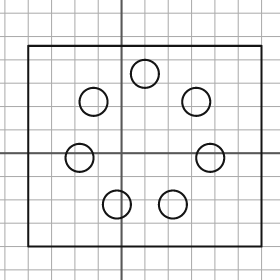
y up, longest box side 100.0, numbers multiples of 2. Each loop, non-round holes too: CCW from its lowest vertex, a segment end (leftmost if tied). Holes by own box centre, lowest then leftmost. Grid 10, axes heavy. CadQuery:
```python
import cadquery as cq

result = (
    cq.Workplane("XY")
    .moveTo(-40.0, -40.0)
    .lineTo(60.0, -40.0)
    .lineTo(60.0, 46.0)
    .lineTo(-40.0, 46.0)
    .close()
    .moveTo(-2.0, -22.0)
    .circle(6.0)
    .moveTo(22.0, -22.0)
    .circle(6.0)
    .moveTo(-18.0, -2.0)
    .circle(6.0)
    .moveTo(38.0, -2.0)
    .circle(6.0)
    .moveTo(-12.0, 22.0)
    .circle(6.0)
    .moveTo(32.0, 22.0)
    .circle(6.0)
    .moveTo(10.0, 34.0)
    .circle(6.0)
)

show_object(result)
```